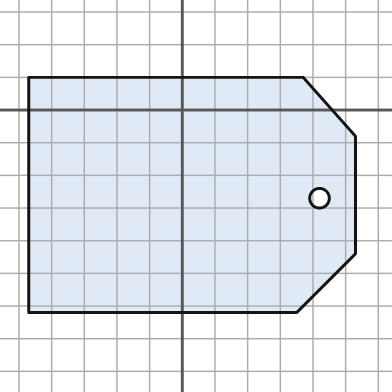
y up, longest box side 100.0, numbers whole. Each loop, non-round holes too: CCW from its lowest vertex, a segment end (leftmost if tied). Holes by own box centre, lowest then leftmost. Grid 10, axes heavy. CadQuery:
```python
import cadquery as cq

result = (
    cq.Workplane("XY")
    .moveTo(-47.0, -62.0)
    .lineTo(35.0, -62.0)
    .lineTo(53.0, -44.0)
    .lineTo(53.0, -8.0)
    .lineTo(37.0, 10.0)
    .lineTo(-47.0, 10.0)
    .close()
    .moveTo(42.0, -27.0)
    .circle(3.0)
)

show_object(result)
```